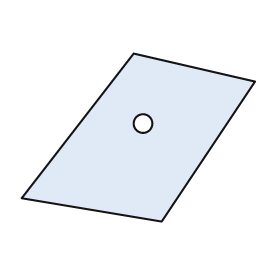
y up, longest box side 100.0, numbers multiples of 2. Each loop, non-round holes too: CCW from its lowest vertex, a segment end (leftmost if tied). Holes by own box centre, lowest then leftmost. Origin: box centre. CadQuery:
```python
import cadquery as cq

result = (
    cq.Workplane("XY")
    .moveTo(10.0, -36.0)
    .lineTo(50.0, 24.0)
    .lineTo(-2.0, 36.0)
    .lineTo(-50.0, -26.0)
    .close()
    .moveTo(2.0, 6.0)
    .circle(4.0)
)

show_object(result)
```